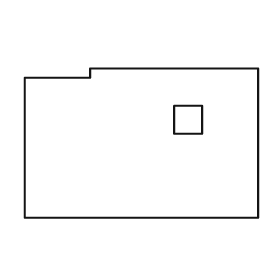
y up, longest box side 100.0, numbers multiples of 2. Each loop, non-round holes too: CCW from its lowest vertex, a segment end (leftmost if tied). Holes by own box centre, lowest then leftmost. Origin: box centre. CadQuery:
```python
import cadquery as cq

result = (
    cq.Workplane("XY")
    .moveTo(-50.0, -32.0)
    .lineTo(50.0, -32.0)
    .lineTo(50.0, 32.0)
    .lineTo(-22.0, 32.0)
    .lineTo(-22.0, 28.0)
    .lineTo(-50.0, 28.0)
    .close()
    .moveTo(14.0, 4.0)
    .lineTo(26.0, 4.0)
    .lineTo(26.0, 16.0)
    .lineTo(14.0, 16.0)
    .close()
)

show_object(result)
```